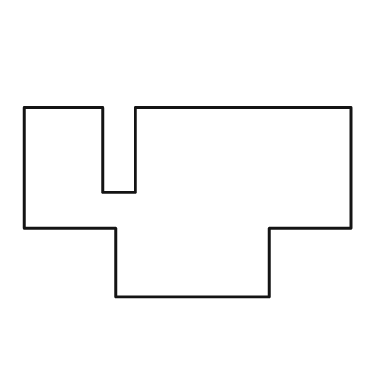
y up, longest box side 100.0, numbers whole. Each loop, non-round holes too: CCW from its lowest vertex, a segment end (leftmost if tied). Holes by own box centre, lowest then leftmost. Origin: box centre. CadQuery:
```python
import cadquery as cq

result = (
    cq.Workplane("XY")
    .moveTo(-22.0, -29.0)
    .lineTo(25.0, -29.0)
    .lineTo(25.0, -8.0)
    .lineTo(50.0, -8.0)
    .lineTo(50.0, 29.0)
    .lineTo(-16.0, 29.0)
    .lineTo(-16.0, 3.0)
    .lineTo(-26.0, 3.0)
    .lineTo(-26.0, 29.0)
    .lineTo(-50.0, 29.0)
    .lineTo(-50.0, -8.0)
    .lineTo(-22.0, -8.0)
    .close()
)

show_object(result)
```